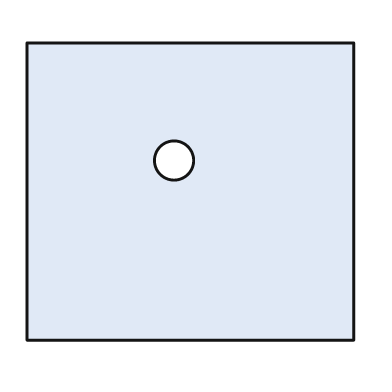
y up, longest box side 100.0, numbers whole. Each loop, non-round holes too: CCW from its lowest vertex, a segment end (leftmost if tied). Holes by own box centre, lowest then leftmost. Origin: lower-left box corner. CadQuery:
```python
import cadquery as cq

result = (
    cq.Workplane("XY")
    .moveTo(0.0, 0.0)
    .lineTo(100.0, 0.0)
    .lineTo(100.0, 91.0)
    .lineTo(0.0, 91.0)
    .close()
    .moveTo(45.0, 55.0)
    .circle(6.0)
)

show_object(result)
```